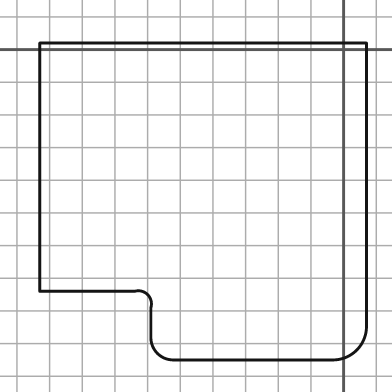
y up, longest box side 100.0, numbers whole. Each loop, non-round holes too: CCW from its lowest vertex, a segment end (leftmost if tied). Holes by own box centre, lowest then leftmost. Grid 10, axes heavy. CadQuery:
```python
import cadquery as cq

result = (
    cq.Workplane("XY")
    .moveTo(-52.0, -95.0)
    .lineTo(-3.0, -95.0)
    .threePointArc((4.0, -92.0), (7.0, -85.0))
    .lineTo(7.0, 2.0)
    .lineTo(-93.0, 2.0)
    .lineTo(-93.0, -74.0)
    .lineTo(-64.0, -74.0)
    .threePointArc((-60.0, -75.0), (-59.0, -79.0))
    .lineTo(-59.0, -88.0)
    .threePointArc((-57.0, -93.0), (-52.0, -95.0))
    .close()
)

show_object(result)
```